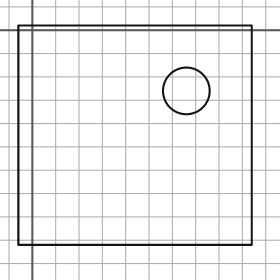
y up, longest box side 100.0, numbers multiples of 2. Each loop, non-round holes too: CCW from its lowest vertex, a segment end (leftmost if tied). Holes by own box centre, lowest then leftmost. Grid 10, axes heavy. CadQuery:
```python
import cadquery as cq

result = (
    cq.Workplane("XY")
    .moveTo(-6.0, -92.0)
    .lineTo(94.0, -92.0)
    .lineTo(94.0, 2.0)
    .lineTo(-6.0, 2.0)
    .close()
    .moveTo(66.0, -26.0)
    .circle(10.0)
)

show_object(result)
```